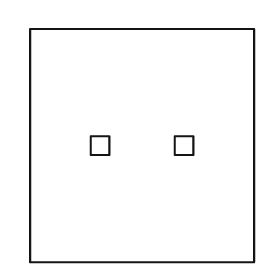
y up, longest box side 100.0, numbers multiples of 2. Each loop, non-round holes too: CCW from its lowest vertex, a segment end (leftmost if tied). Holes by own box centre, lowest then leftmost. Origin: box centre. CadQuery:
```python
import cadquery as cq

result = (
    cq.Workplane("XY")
    .moveTo(-48.0, -50.0)
    .lineTo(48.0, -50.0)
    .lineTo(48.0, 50.0)
    .lineTo(-48.0, 50.0)
    .close()
    .moveTo(-22.0, -4.0)
    .lineTo(-14.0, -4.0)
    .lineTo(-14.0, 4.0)
    .lineTo(-22.0, 4.0)
    .close()
    .moveTo(14.0, -4.0)
    .lineTo(22.0, -4.0)
    .lineTo(22.0, 4.0)
    .lineTo(14.0, 4.0)
    .close()
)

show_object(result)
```